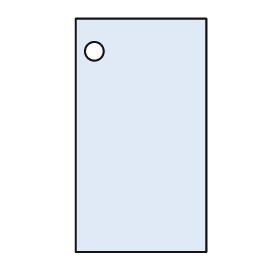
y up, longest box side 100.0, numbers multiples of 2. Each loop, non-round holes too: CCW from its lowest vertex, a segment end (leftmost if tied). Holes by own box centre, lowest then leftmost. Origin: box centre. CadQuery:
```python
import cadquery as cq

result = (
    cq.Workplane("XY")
    .moveTo(-28.0, -50.0)
    .lineTo(28.0, -50.0)
    .lineTo(28.0, 50.0)
    .lineTo(-28.0, 50.0)
    .close()
    .moveTo(-20.0, 36.0)
    .circle(4.0)
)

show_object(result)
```